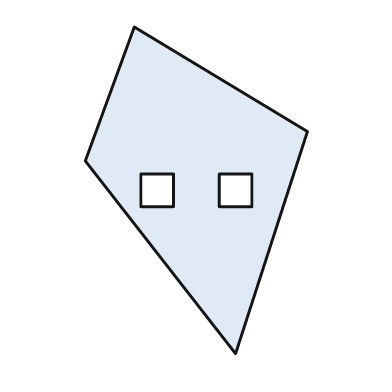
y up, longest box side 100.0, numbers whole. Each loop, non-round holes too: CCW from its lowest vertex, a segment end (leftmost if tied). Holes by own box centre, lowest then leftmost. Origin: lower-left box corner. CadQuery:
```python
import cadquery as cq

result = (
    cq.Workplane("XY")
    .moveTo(46.0, 0.0)
    .lineTo(68.0, 68.0)
    .lineTo(15.0, 100.0)
    .lineTo(0.0, 59.0)
    .close()
    .moveTo(17.0, 45.0)
    .lineTo(27.0, 45.0)
    .lineTo(27.0, 55.0)
    .lineTo(17.0, 55.0)
    .close()
    .moveTo(41.0, 45.0)
    .lineTo(51.0, 45.0)
    .lineTo(51.0, 55.0)
    .lineTo(41.0, 55.0)
    .close()
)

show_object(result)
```